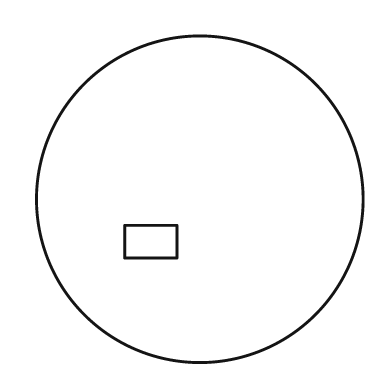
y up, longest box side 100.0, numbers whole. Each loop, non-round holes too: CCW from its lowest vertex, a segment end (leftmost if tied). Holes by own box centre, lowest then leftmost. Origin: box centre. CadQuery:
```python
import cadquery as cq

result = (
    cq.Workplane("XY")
    .moveTo(0.0, 0.0)
    .circle(50.0)
    .moveTo(-23.0, -18.0)
    .lineTo(-7.0, -18.0)
    .lineTo(-7.0, -8.0)
    .lineTo(-23.0, -8.0)
    .close()
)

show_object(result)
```